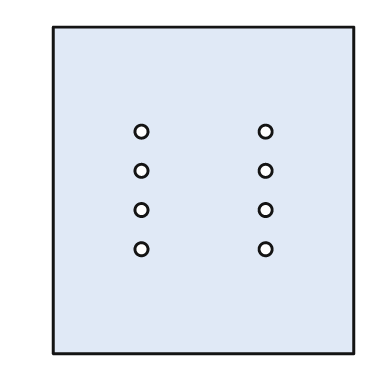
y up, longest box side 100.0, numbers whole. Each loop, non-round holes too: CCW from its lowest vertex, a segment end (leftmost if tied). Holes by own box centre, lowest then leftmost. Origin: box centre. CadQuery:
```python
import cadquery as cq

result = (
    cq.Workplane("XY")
    .moveTo(-46.0, -50.0)
    .lineTo(46.0, -50.0)
    .lineTo(46.0, 50.0)
    .lineTo(-46.0, 50.0)
    .close()
    .moveTo(-19.0, -18.0)
    .circle(2.0)
    .moveTo(19.0, -18.0)
    .circle(2.0)
    .moveTo(-19.0, -6.0)
    .circle(2.0)
    .moveTo(19.0, -6.0)
    .circle(2.0)
    .moveTo(-19.0, 6.0)
    .circle(2.0)
    .moveTo(19.0, 6.0)
    .circle(2.0)
    .moveTo(-19.0, 18.0)
    .circle(2.0)
    .moveTo(19.0, 18.0)
    .circle(2.0)
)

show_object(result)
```